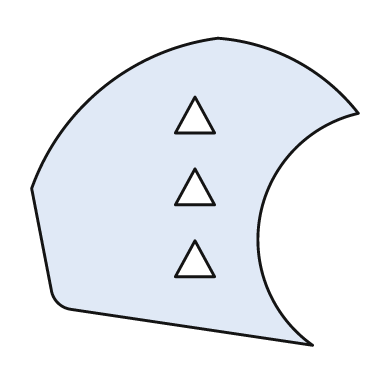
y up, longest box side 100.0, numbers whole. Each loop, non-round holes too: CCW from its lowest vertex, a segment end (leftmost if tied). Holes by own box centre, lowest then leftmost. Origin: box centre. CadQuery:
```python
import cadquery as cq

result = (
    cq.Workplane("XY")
    .moveTo(36.0, -47.0)
    .threePointArc((20.0, -7.0), (50.0, 24.0))
    .threePointArc((31.0, 40.0), (7.0, 47.0))
    .threePointArc((-28.0, 32.0), (-50.0, 1.0))
    .lineTo(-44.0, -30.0)
    .threePointArc((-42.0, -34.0), (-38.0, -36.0))
    .close()
    .moveTo(-6.0, -26.0)
    .lineTo(6.0, -26.0)
    .lineTo(0.0, -15.0)
    .close()
    .moveTo(-6.0, -4.0)
    .lineTo(6.0, -4.0)
    .lineTo(0.0, 7.0)
    .close()
    .moveTo(-6.0, 18.0)
    .lineTo(6.0, 18.0)
    .lineTo(0.0, 29.0)
    .close()
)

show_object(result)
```